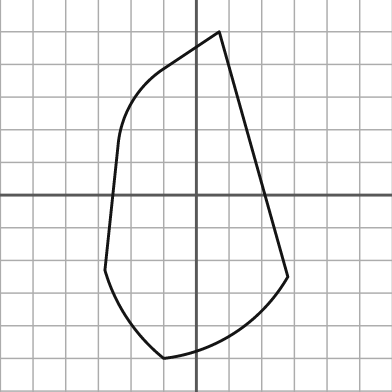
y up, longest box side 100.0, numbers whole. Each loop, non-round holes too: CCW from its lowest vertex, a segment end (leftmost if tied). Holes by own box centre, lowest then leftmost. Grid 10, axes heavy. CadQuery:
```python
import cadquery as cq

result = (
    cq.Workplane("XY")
    .moveTo(-10.0, -50.0)
    .threePointArc((12.0, -42.0), (28.0, -25.0))
    .lineTo(7.0, 50.0)
    .lineTo(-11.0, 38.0)
    .threePointArc((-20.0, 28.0), (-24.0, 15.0))
    .lineTo(-28.0, -23.0)
    .threePointArc((-21.0, -38.0), (-10.0, -50.0))
    .close()
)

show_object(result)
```